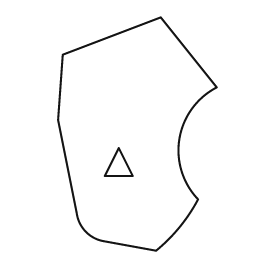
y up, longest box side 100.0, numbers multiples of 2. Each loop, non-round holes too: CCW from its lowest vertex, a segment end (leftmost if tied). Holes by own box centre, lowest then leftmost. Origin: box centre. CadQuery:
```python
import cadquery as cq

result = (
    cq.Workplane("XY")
    .moveTo(8.0, -50.0)
    .threePointArc((18.0, -40.0), (26.0, -28.0))
    .threePointArc((18.0, -2.0), (34.0, 20.0))
    .lineTo(10.0, 50.0)
    .lineTo(-32.0, 34.0)
    .lineTo(-34.0, 6.0)
    .lineTo(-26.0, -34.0)
    .threePointArc((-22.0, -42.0), (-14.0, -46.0))
    .close()
    .moveTo(-14.0, -18.0)
    .lineTo(-2.0, -18.0)
    .lineTo(-8.0, -6.0)
    .close()
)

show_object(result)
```